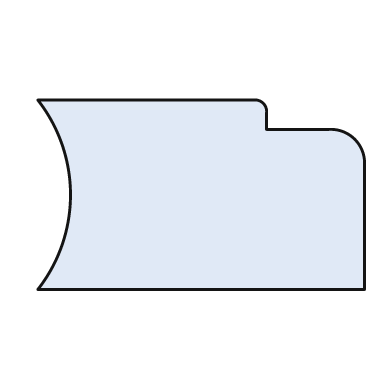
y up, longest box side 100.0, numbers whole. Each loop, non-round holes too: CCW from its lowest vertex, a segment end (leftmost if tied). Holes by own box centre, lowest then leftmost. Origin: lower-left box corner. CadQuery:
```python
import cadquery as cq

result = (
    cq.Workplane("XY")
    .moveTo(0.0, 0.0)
    .lineTo(100.0, 0.0)
    .lineTo(100.0, 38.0)
    .threePointArc((97.0, 46.0), (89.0, 49.0))
    .lineTo(70.0, 49.0)
    .lineTo(70.0, 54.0)
    .threePointArc((69.0, 57.0), (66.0, 58.0))
    .lineTo(0.0, 58.0)
    .threePointArc((10.0, 29.0), (0.0, 0.0))
    .close()
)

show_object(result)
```